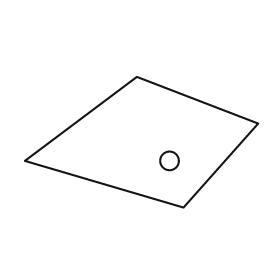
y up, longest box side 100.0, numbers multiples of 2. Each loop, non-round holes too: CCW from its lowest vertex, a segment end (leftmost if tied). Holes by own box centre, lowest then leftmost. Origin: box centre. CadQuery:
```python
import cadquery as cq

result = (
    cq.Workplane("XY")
    .moveTo(18.0, -28.0)
    .lineTo(50.0, 8.0)
    .lineTo(-2.0, 28.0)
    .lineTo(-50.0, -8.0)
    .close()
    .moveTo(12.0, -8.0)
    .circle(4.0)
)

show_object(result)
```